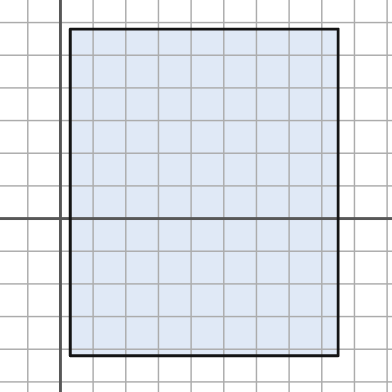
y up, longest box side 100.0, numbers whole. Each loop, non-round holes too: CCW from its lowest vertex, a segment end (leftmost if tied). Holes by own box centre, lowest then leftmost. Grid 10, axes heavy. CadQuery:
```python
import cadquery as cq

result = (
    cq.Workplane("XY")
    .moveTo(3.0, -42.0)
    .lineTo(85.0, -42.0)
    .lineTo(85.0, 58.0)
    .lineTo(3.0, 58.0)
    .close()
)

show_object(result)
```